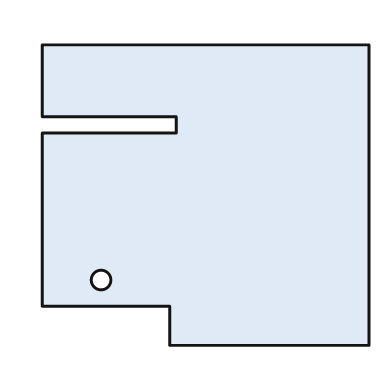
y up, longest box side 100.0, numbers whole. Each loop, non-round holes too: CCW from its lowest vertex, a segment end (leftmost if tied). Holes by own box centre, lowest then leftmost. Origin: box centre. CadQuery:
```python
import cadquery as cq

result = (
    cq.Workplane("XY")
    .moveTo(-11.0, -46.0)
    .lineTo(50.0, -46.0)
    .lineTo(50.0, 46.0)
    .lineTo(-50.0, 46.0)
    .lineTo(-50.0, 24.0)
    .lineTo(-9.0, 24.0)
    .lineTo(-9.0, 19.0)
    .lineTo(-50.0, 19.0)
    .lineTo(-50.0, -34.0)
    .lineTo(-11.0, -34.0)
    .close()
    .moveTo(-32.0, -26.0)
    .circle(3.0)
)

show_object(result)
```